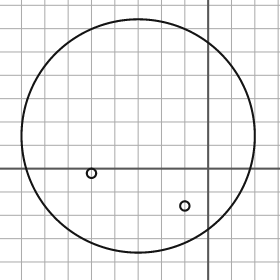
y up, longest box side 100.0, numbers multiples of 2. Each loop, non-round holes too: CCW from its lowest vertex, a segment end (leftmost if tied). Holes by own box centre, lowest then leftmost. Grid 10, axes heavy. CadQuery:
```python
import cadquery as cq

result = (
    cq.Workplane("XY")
    .moveTo(-30.0, 14.0)
    .circle(50.0)
    .moveTo(-10.0, -16.0)
    .circle(2.0)
    .moveTo(-50.0, -2.0)
    .circle(2.0)
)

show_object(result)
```